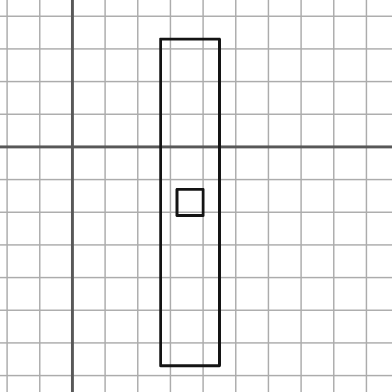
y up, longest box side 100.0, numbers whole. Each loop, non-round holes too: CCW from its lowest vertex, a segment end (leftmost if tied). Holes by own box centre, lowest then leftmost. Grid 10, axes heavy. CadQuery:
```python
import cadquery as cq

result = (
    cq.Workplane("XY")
    .moveTo(27.0, -67.0)
    .lineTo(45.0, -67.0)
    .lineTo(45.0, 33.0)
    .lineTo(27.0, 33.0)
    .close()
    .moveTo(32.0, -21.0)
    .lineTo(40.0, -21.0)
    .lineTo(40.0, -13.0)
    .lineTo(32.0, -13.0)
    .close()
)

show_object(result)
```